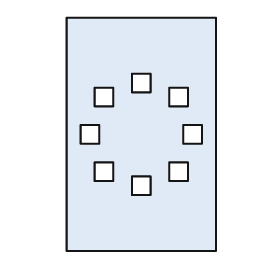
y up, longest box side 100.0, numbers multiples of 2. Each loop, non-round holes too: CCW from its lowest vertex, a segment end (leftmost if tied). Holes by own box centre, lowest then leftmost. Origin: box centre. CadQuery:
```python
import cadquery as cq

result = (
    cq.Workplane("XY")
    .moveTo(-32.0, -50.0)
    .lineTo(32.0, -50.0)
    .lineTo(32.0, 50.0)
    .lineTo(-32.0, 50.0)
    .close()
    .moveTo(-4.0, -26.0)
    .lineTo(4.0, -26.0)
    .lineTo(4.0, -18.0)
    .lineTo(-4.0, -18.0)
    .close()
    .moveTo(-20.0, -20.0)
    .lineTo(-12.0, -20.0)
    .lineTo(-12.0, -12.0)
    .lineTo(-20.0, -12.0)
    .close()
    .moveTo(12.0, -20.0)
    .lineTo(20.0, -20.0)
    .lineTo(20.0, -12.0)
    .lineTo(12.0, -12.0)
    .close()
    .moveTo(-26.0, -4.0)
    .lineTo(-18.0, -4.0)
    .lineTo(-18.0, 4.0)
    .lineTo(-26.0, 4.0)
    .close()
    .moveTo(18.0, -4.0)
    .lineTo(26.0, -4.0)
    .lineTo(26.0, 4.0)
    .lineTo(18.0, 4.0)
    .close()
    .moveTo(-20.0, 12.0)
    .lineTo(-12.0, 12.0)
    .lineTo(-12.0, 20.0)
    .lineTo(-20.0, 20.0)
    .close()
    .moveTo(12.0, 12.0)
    .lineTo(20.0, 12.0)
    .lineTo(20.0, 20.0)
    .lineTo(12.0, 20.0)
    .close()
    .moveTo(-4.0, 18.0)
    .lineTo(4.0, 18.0)
    .lineTo(4.0, 26.0)
    .lineTo(-4.0, 26.0)
    .close()
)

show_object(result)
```